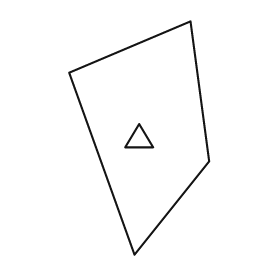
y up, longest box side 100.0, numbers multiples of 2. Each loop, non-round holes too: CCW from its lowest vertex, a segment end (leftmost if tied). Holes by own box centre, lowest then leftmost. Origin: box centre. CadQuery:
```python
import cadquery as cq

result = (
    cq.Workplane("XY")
    .moveTo(-2.0, -50.0)
    .lineTo(30.0, -10.0)
    .lineTo(22.0, 50.0)
    .lineTo(-30.0, 28.0)
    .close()
    .moveTo(-6.0, -4.0)
    .lineTo(6.0, -4.0)
    .lineTo(0.0, 6.0)
    .close()
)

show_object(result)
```